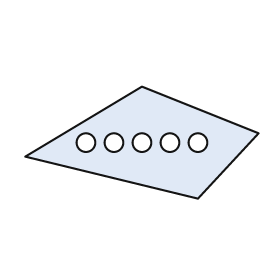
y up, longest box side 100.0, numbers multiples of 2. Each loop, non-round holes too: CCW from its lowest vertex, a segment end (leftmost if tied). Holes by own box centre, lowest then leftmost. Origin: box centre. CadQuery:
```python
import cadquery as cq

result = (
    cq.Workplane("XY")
    .moveTo(24.0, -24.0)
    .lineTo(50.0, 4.0)
    .lineTo(0.0, 24.0)
    .lineTo(-50.0, -6.0)
    .close()
    .moveTo(-24.0, 0.0)
    .circle(4.0)
    .moveTo(-12.0, 0.0)
    .circle(4.0)
    .moveTo(0.0, 0.0)
    .circle(4.0)
    .moveTo(12.0, 0.0)
    .circle(4.0)
    .moveTo(24.0, 0.0)
    .circle(4.0)
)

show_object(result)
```